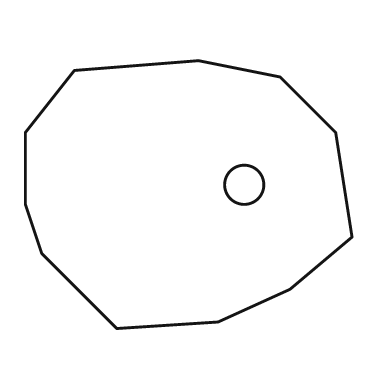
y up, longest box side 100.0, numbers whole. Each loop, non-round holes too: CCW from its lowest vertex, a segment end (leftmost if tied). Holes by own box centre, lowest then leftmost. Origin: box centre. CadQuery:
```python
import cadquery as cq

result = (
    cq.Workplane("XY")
    .moveTo(-22.0, -41.0)
    .lineTo(9.0, -39.0)
    .lineTo(31.0, -29.0)
    .lineTo(50.0, -13.0)
    .lineTo(45.0, 19.0)
    .lineTo(28.0, 36.0)
    .lineTo(3.0, 41.0)
    .lineTo(-35.0, 38.0)
    .lineTo(-50.0, 19.0)
    .lineTo(-50.0, -3.0)
    .lineTo(-45.0, -18.0)
    .close()
    .moveTo(17.0, 3.0)
    .circle(6.0)
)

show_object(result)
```